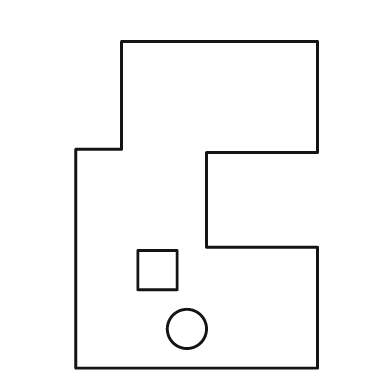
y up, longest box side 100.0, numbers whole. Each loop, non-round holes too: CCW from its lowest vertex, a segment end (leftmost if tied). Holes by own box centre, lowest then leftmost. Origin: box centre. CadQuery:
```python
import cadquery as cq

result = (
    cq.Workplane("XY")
    .moveTo(-37.0, -50.0)
    .lineTo(37.0, -50.0)
    .lineTo(37.0, -13.0)
    .lineTo(3.0, -13.0)
    .lineTo(3.0, 16.0)
    .lineTo(37.0, 16.0)
    .lineTo(37.0, 50.0)
    .lineTo(-23.0, 50.0)
    .lineTo(-23.0, 17.0)
    .lineTo(-37.0, 17.0)
    .close()
    .moveTo(-3.0, -38.0)
    .circle(6.0)
    .moveTo(-18.0, -26.0)
    .lineTo(-6.0, -26.0)
    .lineTo(-6.0, -14.0)
    .lineTo(-18.0, -14.0)
    .close()
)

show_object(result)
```